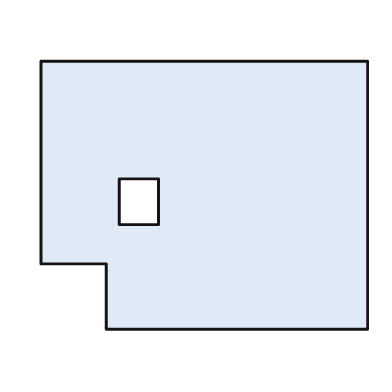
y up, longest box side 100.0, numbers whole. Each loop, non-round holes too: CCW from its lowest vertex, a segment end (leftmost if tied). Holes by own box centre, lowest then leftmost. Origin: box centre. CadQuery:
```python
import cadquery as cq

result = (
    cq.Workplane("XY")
    .moveTo(-30.0, -41.0)
    .lineTo(50.0, -41.0)
    .lineTo(50.0, 41.0)
    .lineTo(-50.0, 41.0)
    .lineTo(-50.0, -21.0)
    .lineTo(-30.0, -21.0)
    .close()
    .moveTo(-26.0, -9.0)
    .lineTo(-14.0, -9.0)
    .lineTo(-14.0, 5.0)
    .lineTo(-26.0, 5.0)
    .close()
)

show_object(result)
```